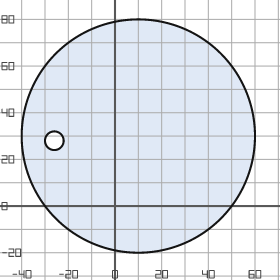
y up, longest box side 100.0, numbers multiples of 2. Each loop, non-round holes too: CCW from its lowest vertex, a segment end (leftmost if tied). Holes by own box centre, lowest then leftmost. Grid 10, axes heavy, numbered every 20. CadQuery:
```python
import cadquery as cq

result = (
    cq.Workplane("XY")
    .moveTo(10.0, 30.0)
    .circle(50.0)
    .moveTo(-26.0, 28.0)
    .circle(4.0)
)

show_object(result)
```